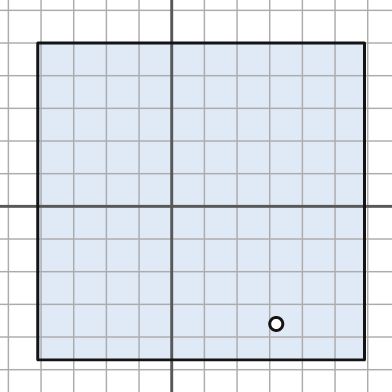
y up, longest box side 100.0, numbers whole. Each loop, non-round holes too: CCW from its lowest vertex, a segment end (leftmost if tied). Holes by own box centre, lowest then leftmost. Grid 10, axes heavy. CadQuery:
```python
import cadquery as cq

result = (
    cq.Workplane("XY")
    .moveTo(-41.0, -47.0)
    .lineTo(59.0, -47.0)
    .lineTo(59.0, 50.0)
    .lineTo(-41.0, 50.0)
    .close()
    .moveTo(32.0, -36.0)
    .circle(2.0)
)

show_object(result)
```